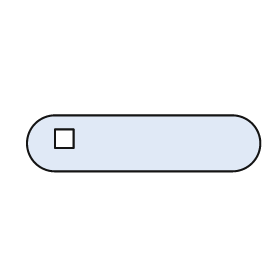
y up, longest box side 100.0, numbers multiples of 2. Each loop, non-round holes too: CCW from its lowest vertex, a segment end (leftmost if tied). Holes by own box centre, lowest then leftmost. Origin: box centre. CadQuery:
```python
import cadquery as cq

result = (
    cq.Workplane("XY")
    .moveTo(-38.0, -12.0)
    .lineTo(38.0, -12.0)
    .threePointArc((50.0, 0.0), (38.0, 12.0))
    .lineTo(-38.0, 12.0)
    .threePointArc((-50.0, 0.0), (-38.0, -12.0))
    .close()
    .moveTo(-38.0, -2.0)
    .lineTo(-30.0, -2.0)
    .lineTo(-30.0, 6.0)
    .lineTo(-38.0, 6.0)
    .close()
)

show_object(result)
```